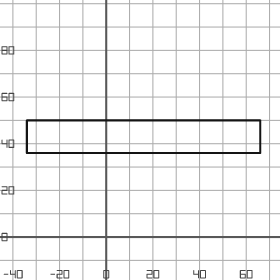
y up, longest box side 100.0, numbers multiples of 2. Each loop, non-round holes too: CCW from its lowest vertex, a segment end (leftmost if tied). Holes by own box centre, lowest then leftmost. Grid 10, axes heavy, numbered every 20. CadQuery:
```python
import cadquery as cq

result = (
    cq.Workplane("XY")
    .moveTo(-34.0, 36.0)
    .lineTo(66.0, 36.0)
    .lineTo(66.0, 50.0)
    .lineTo(-34.0, 50.0)
    .close()
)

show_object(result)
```